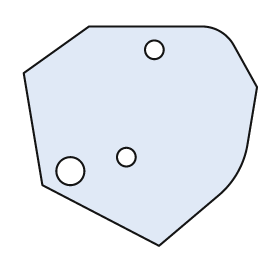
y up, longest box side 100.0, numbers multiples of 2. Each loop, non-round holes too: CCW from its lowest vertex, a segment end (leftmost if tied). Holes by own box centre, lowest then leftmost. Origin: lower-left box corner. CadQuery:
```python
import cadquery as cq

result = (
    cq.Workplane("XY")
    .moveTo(58.0, 0.0)
    .lineTo(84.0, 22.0)
    .threePointArc((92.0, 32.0), (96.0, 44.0))
    .lineTo(100.0, 68.0)
    .lineTo(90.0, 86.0)
    .threePointArc((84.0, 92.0), (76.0, 94.0))
    .lineTo(28.0, 94.0)
    .lineTo(0.0, 74.0)
    .lineTo(8.0, 26.0)
    .close()
    .moveTo(20.0, 32.0)
    .circle(6.0)
    .moveTo(44.0, 38.0)
    .circle(4.0)
    .moveTo(56.0, 84.0)
    .circle(4.0)
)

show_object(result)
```